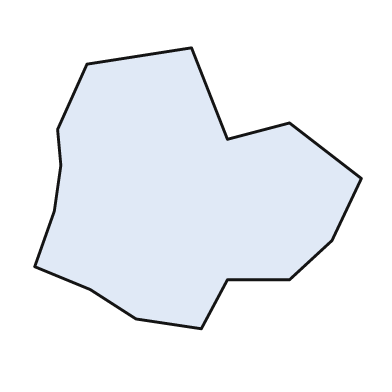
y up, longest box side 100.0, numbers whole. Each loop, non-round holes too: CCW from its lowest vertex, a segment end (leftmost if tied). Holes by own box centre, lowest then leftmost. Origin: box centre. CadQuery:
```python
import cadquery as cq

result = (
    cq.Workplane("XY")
    .moveTo(1.0, -43.0)
    .lineTo(9.0, -28.0)
    .lineTo(28.0, -28.0)
    .lineTo(41.0, -16.0)
    .lineTo(50.0, 3.0)
    .lineTo(28.0, 20.0)
    .lineTo(9.0, 15.0)
    .lineTo(-2.0, 43.0)
    .lineTo(-34.0, 38.0)
    .lineTo(-43.0, 18.0)
    .lineTo(-42.0, 7.0)
    .lineTo(-44.0, -7.0)
    .lineTo(-50.0, -24.0)
    .lineTo(-33.0, -31.0)
    .lineTo(-19.0, -40.0)
    .close()
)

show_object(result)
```